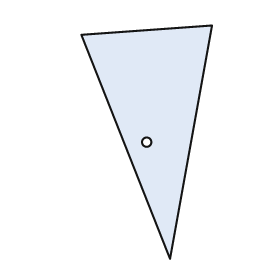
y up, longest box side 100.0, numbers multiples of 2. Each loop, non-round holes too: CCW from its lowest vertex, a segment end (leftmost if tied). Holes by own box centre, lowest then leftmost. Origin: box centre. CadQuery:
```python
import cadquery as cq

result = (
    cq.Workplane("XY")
    .moveTo(10.0, -50.0)
    .lineTo(28.0, 50.0)
    .lineTo(-28.0, 46.0)
    .close()
    .moveTo(0.0, 0.0)
    .circle(2.0)
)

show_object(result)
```